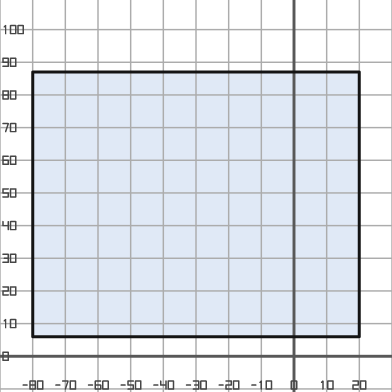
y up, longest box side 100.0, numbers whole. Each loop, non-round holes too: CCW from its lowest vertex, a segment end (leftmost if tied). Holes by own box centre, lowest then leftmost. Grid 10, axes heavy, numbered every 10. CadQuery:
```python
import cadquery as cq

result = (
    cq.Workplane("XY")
    .moveTo(-80.0, 6.0)
    .lineTo(20.0, 6.0)
    .lineTo(20.0, 87.0)
    .lineTo(-80.0, 87.0)
    .close()
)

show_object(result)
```